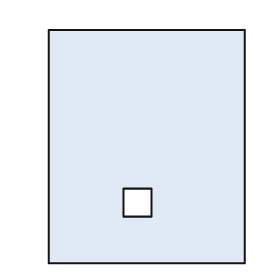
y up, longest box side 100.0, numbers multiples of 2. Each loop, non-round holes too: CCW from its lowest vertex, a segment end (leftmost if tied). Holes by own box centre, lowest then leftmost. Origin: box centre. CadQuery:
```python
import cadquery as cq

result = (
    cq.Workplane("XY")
    .moveTo(-42.0, -50.0)
    .lineTo(42.0, -50.0)
    .lineTo(42.0, 50.0)
    .lineTo(-42.0, 50.0)
    .close()
    .moveTo(-10.0, -30.0)
    .lineTo(2.0, -30.0)
    .lineTo(2.0, -18.0)
    .lineTo(-10.0, -18.0)
    .close()
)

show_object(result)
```